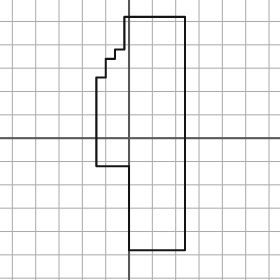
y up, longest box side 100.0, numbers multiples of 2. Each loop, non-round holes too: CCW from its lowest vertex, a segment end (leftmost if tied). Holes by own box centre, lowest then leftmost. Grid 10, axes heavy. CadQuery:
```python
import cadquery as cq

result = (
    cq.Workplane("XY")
    .moveTo(0.0, -48.0)
    .lineTo(24.0, -48.0)
    .lineTo(24.0, 52.0)
    .lineTo(-2.0, 52.0)
    .lineTo(-2.0, 38.0)
    .lineTo(-6.0, 38.0)
    .lineTo(-6.0, 34.0)
    .lineTo(-10.0, 34.0)
    .lineTo(-10.0, 26.0)
    .lineTo(-14.0, 26.0)
    .lineTo(-14.0, -12.0)
    .lineTo(0.0, -12.0)
    .close()
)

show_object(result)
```